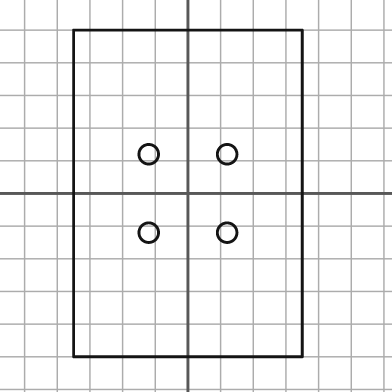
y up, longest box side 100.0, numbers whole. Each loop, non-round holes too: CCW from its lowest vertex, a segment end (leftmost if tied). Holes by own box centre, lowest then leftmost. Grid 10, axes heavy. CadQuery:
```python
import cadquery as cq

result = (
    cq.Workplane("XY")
    .moveTo(-35.0, -50.0)
    .lineTo(35.0, -50.0)
    .lineTo(35.0, 50.0)
    .lineTo(-35.0, 50.0)
    .close()
    .moveTo(-12.0, -12.0)
    .circle(3.0)
    .moveTo(12.0, -12.0)
    .circle(3.0)
    .moveTo(-12.0, 12.0)
    .circle(3.0)
    .moveTo(12.0, 12.0)
    .circle(3.0)
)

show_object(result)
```